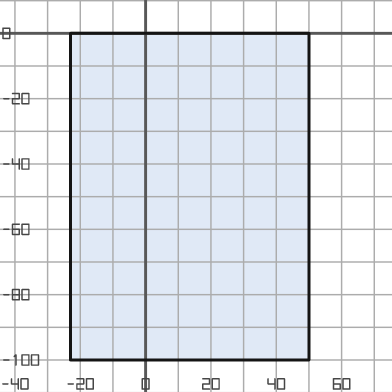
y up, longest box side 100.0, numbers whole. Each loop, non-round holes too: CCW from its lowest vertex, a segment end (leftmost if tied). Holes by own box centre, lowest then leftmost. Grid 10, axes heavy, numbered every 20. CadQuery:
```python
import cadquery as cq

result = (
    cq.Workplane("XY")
    .moveTo(-23.0, -100.0)
    .lineTo(50.0, -100.0)
    .lineTo(50.0, 0.0)
    .lineTo(-23.0, 0.0)
    .close()
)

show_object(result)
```